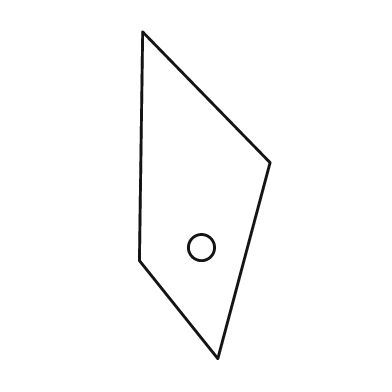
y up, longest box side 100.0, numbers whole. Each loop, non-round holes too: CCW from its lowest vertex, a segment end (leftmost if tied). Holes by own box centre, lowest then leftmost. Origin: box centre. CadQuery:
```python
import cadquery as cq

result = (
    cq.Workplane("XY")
    .moveTo(4.0, -50.0)
    .lineTo(20.0, 10.0)
    .lineTo(-19.0, 50.0)
    .lineTo(-20.0, -20.0)
    .close()
    .moveTo(-1.0, -16.0)
    .circle(4.0)
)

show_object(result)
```